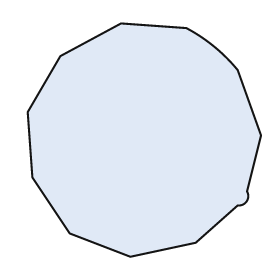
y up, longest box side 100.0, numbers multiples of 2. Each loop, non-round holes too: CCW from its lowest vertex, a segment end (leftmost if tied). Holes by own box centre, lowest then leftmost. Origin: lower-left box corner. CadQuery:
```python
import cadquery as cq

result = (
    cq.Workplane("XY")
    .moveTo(44.0, 0.0)
    .lineTo(72.0, 6.0)
    .lineTo(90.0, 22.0)
    .threePointArc((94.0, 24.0), (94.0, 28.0))
    .lineTo(100.0, 52.0)
    .lineTo(90.0, 80.0)
    .threePointArc((80.0, 90.0), (68.0, 98.0))
    .lineTo(40.0, 100.0)
    .lineTo(14.0, 86.0)
    .lineTo(0.0, 62.0)
    .lineTo(2.0, 34.0)
    .lineTo(18.0, 10.0)
    .close()
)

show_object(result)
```